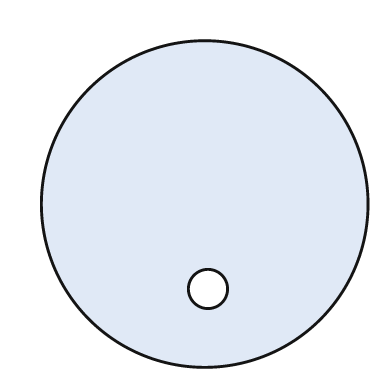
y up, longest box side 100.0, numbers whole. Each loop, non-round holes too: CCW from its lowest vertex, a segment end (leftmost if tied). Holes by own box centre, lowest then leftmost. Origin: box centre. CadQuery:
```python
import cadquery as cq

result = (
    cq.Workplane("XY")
    .moveTo(0.0, 0.0)
    .circle(50.0)
    .moveTo(1.0, -26.0)
    .circle(6.0)
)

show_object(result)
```